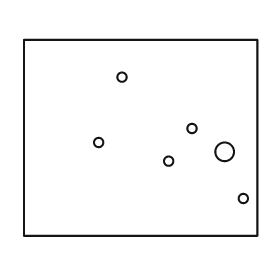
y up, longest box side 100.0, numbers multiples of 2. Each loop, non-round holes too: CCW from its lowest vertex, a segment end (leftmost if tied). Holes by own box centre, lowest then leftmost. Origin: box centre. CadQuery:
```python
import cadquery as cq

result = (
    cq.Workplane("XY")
    .moveTo(-50.0, -42.0)
    .lineTo(50.0, -42.0)
    .lineTo(50.0, 42.0)
    .lineTo(-50.0, 42.0)
    .close()
    .moveTo(44.0, -26.0)
    .circle(2.0)
    .moveTo(12.0, -10.0)
    .circle(2.0)
    .moveTo(36.0, -6.0)
    .circle(4.0)
    .moveTo(-18.0, -2.0)
    .circle(2.0)
    .moveTo(22.0, 4.0)
    .circle(2.0)
    .moveTo(-8.0, 26.0)
    .circle(2.0)
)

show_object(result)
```